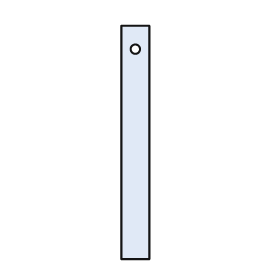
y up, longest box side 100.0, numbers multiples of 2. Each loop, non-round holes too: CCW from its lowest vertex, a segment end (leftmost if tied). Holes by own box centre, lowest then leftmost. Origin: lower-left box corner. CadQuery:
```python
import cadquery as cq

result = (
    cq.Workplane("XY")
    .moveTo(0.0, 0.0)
    .lineTo(12.0, 0.0)
    .lineTo(12.0, 100.0)
    .lineTo(0.0, 100.0)
    .close()
    .moveTo(6.0, 90.0)
    .circle(2.0)
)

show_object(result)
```